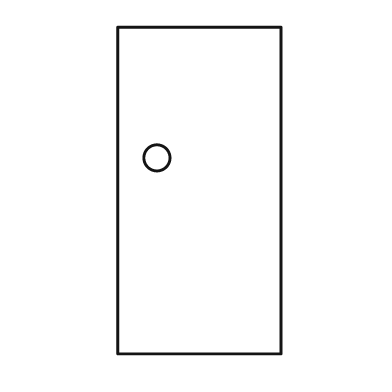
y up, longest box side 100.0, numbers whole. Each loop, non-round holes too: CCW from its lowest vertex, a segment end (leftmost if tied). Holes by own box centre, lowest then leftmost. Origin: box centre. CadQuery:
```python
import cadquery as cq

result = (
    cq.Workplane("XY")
    .moveTo(-25.0, -50.0)
    .lineTo(25.0, -50.0)
    .lineTo(25.0, 50.0)
    .lineTo(-25.0, 50.0)
    .close()
    .moveTo(-13.0, 10.0)
    .circle(4.0)
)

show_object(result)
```